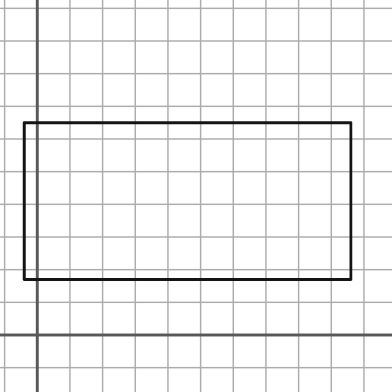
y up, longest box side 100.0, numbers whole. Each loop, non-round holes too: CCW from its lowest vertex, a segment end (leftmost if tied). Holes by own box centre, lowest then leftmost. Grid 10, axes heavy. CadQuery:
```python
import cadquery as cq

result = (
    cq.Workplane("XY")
    .moveTo(-4.0, 17.0)
    .lineTo(96.0, 17.0)
    .lineTo(96.0, 65.0)
    .lineTo(-4.0, 65.0)
    .close()
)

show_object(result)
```